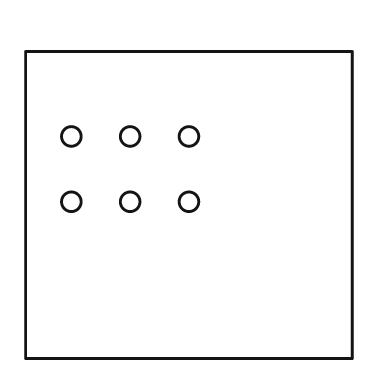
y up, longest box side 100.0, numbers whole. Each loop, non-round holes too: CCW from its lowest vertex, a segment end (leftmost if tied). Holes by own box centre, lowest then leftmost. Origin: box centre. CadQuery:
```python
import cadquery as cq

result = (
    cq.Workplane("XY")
    .moveTo(-50.0, -47.0)
    .lineTo(50.0, -47.0)
    .lineTo(50.0, 47.0)
    .lineTo(-50.0, 47.0)
    .close()
    .moveTo(-36.0, 1.0)
    .circle(3.0)
    .moveTo(-18.0, 1.0)
    .circle(3.0)
    .moveTo(0.0, 1.0)
    .circle(3.0)
    .moveTo(-36.0, 21.0)
    .circle(3.0)
    .moveTo(-18.0, 21.0)
    .circle(3.0)
    .moveTo(0.0, 21.0)
    .circle(3.0)
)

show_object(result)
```